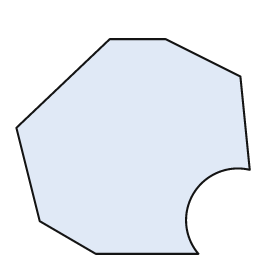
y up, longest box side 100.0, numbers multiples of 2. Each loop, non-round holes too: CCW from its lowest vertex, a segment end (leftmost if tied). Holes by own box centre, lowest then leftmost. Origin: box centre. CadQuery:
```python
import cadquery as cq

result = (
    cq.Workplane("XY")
    .moveTo(-16.0, -46.0)
    .lineTo(28.0, -46.0)
    .threePointArc((26.0, -20.0), (50.0, -10.0))
    .lineTo(46.0, 30.0)
    .lineTo(14.0, 46.0)
    .lineTo(-10.0, 46.0)
    .lineTo(-50.0, 8.0)
    .lineTo(-40.0, -32.0)
    .close()
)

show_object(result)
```